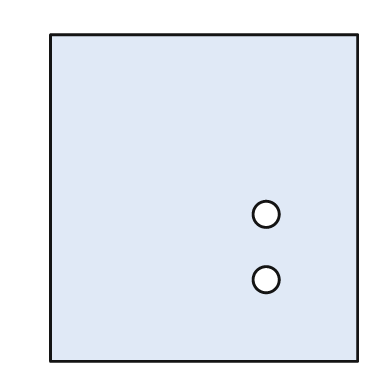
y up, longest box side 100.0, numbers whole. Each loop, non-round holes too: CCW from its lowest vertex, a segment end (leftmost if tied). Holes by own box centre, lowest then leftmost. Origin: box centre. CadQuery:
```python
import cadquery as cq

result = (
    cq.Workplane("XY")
    .moveTo(-47.0, -50.0)
    .lineTo(47.0, -50.0)
    .lineTo(47.0, 50.0)
    .lineTo(-47.0, 50.0)
    .close()
    .moveTo(19.0, -25.0)
    .circle(4.0)
    .moveTo(19.0, -5.0)
    .circle(4.0)
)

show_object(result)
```